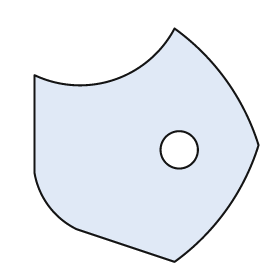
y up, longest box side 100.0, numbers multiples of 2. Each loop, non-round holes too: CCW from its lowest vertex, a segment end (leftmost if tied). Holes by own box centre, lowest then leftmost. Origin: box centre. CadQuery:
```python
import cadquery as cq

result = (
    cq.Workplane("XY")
    .moveTo(12.0, -50.0)
    .threePointArc((34.0, -28.0), (48.0, 0.0))
    .threePointArc((34.0, 28.0), (12.0, 50.0))
    .threePointArc((-14.0, 28.0), (-48.0, 30.0))
    .lineTo(-48.0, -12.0)
    .threePointArc((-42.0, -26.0), (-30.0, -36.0))
    .close()
    .moveTo(14.0, -2.0)
    .circle(8.0)
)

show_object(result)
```